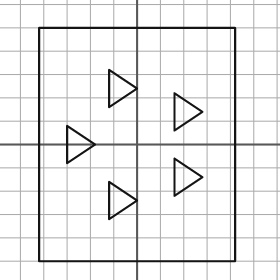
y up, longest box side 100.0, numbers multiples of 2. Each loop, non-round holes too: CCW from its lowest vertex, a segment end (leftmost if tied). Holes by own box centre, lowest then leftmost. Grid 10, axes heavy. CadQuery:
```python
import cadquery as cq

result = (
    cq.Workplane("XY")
    .moveTo(-42.0, -50.0)
    .lineTo(42.0, -50.0)
    .lineTo(42.0, 50.0)
    .lineTo(-42.0, 50.0)
    .close()
    .moveTo(-12.0, -32.0)
    .lineTo(0.0, -24.0)
    .lineTo(-12.0, -16.0)
    .close()
    .moveTo(16.0, -22.0)
    .lineTo(28.0, -14.0)
    .lineTo(16.0, -6.0)
    .close()
    .moveTo(-30.0, -8.0)
    .lineTo(-18.0, 0.0)
    .lineTo(-30.0, 8.0)
    .close()
    .moveTo(16.0, 6.0)
    .lineTo(28.0, 14.0)
    .lineTo(16.0, 22.0)
    .close()
    .moveTo(-12.0, 16.0)
    .lineTo(0.0, 24.0)
    .lineTo(-12.0, 32.0)
    .close()
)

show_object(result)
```